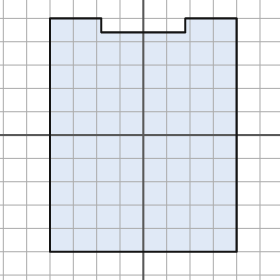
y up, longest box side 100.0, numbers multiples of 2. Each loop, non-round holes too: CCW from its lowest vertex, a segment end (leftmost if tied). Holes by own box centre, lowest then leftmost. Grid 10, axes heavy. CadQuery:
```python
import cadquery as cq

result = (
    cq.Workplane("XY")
    .moveTo(-40.0, -50.0)
    .lineTo(40.0, -50.0)
    .lineTo(40.0, 50.0)
    .lineTo(18.0, 50.0)
    .lineTo(18.0, 44.0)
    .lineTo(-18.0, 44.0)
    .lineTo(-18.0, 50.0)
    .lineTo(-40.0, 50.0)
    .close()
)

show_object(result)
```